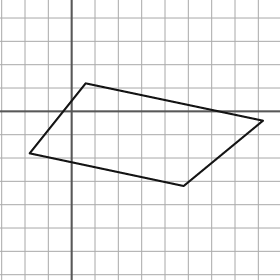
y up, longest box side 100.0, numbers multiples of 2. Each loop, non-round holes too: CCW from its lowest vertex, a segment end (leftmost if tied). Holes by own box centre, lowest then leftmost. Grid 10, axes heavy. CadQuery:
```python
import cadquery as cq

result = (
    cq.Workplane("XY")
    .moveTo(48.0, -32.0)
    .lineTo(82.0, -4.0)
    .lineTo(6.0, 12.0)
    .lineTo(-18.0, -18.0)
    .close()
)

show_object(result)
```